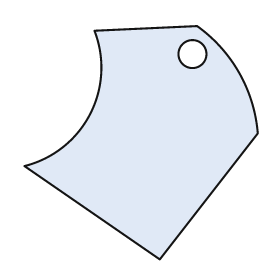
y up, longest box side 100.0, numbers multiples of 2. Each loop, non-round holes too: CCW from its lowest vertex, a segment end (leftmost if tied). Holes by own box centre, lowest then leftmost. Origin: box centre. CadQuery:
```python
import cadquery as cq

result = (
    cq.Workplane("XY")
    .moveTo(8.0, -50.0)
    .lineTo(50.0, 4.0)
    .threePointArc((42.0, 30.0), (24.0, 50.0))
    .lineTo(-20.0, 48.0)
    .threePointArc((-22.0, 12.0), (-50.0, -10.0))
    .close()
    .moveTo(22.0, 38.0)
    .circle(6.0)
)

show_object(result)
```